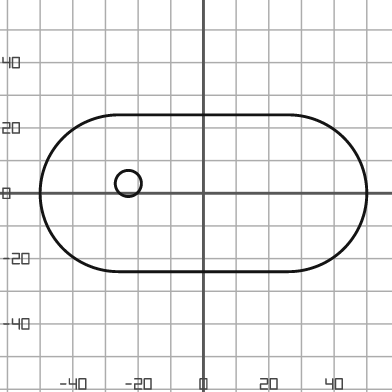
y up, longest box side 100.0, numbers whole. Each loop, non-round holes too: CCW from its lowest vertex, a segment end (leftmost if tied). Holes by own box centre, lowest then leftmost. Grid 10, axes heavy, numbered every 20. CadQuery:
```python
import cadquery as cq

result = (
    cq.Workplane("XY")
    .moveTo(-26.0, -24.0)
    .lineTo(26.0, -24.0)
    .threePointArc((50.0, 0.0), (26.0, 24.0))
    .lineTo(-26.0, 24.0)
    .threePointArc((-50.0, 0.0), (-26.0, -24.0))
    .close()
    .moveTo(-23.0, 3.0)
    .circle(4.0)
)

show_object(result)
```